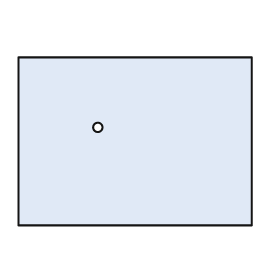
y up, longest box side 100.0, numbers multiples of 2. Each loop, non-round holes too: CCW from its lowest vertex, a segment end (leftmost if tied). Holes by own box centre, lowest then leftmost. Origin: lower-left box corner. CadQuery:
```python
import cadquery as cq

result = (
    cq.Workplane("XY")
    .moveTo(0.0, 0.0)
    .lineTo(100.0, 0.0)
    .lineTo(100.0, 72.0)
    .lineTo(0.0, 72.0)
    .close()
    .moveTo(34.0, 42.0)
    .circle(2.0)
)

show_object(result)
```